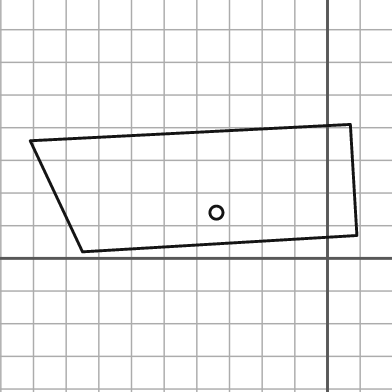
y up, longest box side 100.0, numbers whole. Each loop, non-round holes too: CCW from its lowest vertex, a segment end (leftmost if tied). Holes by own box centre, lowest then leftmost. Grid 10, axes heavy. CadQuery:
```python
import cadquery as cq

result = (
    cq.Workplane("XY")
    .moveTo(-75.0, 2.0)
    .lineTo(9.0, 7.0)
    .lineTo(7.0, 41.0)
    .lineTo(-91.0, 36.0)
    .close()
    .moveTo(-34.0, 14.0)
    .circle(2.0)
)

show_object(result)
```